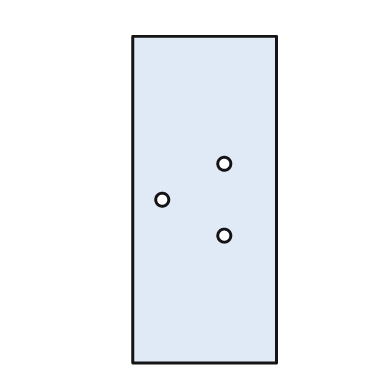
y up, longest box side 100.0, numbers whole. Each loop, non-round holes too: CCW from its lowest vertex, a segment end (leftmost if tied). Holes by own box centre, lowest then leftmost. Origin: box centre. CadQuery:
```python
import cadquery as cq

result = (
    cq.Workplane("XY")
    .moveTo(-22.0, -50.0)
    .lineTo(22.0, -50.0)
    .lineTo(22.0, 50.0)
    .lineTo(-22.0, 50.0)
    .close()
    .moveTo(6.0, -11.0)
    .circle(2.0)
    .moveTo(-13.0, 0.0)
    .circle(2.0)
    .moveTo(6.0, 11.0)
    .circle(2.0)
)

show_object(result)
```